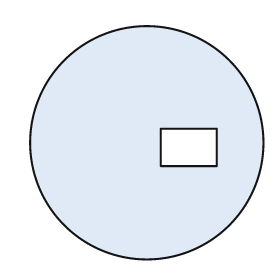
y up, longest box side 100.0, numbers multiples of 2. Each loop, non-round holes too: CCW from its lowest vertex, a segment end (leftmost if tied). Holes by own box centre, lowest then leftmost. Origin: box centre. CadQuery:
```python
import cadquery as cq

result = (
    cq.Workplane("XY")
    .moveTo(0.0, 0.0)
    .circle(50.0)
    .moveTo(6.0, -10.0)
    .lineTo(30.0, -10.0)
    .lineTo(30.0, 6.0)
    .lineTo(6.0, 6.0)
    .close()
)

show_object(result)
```